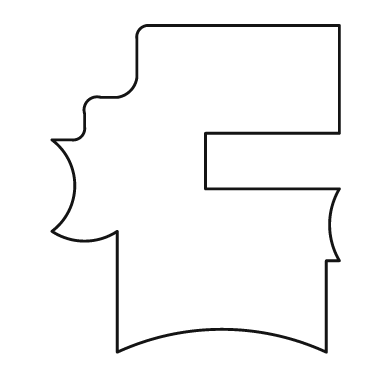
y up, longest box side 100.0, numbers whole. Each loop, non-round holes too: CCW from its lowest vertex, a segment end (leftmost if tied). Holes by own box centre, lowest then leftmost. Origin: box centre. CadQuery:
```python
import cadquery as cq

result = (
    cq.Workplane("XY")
    .moveTo(-24.0, -50.0)
    .threePointArc((8.0, -43.0), (40.0, -50.0))
    .lineTo(40.0, -22.0)
    .lineTo(44.0, -22.0)
    .threePointArc((41.0, -11.0), (44.0, 0.0))
    .lineTo(3.0, 0.0)
    .lineTo(3.0, 17.0)
    .lineTo(44.0, 17.0)
    .lineTo(44.0, 50.0)
    .lineTo(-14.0, 50.0)
    .threePointArc((-17.0, 49.0), (-18.0, 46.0))
    .lineTo(-18.0, 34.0)
    .threePointArc((-20.0, 30.0), (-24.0, 28.0))
    .lineTo(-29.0, 28.0)
    .threePointArc((-33.0, 27.0), (-34.0, 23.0))
    .lineTo(-34.0, 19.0)
    .threePointArc((-35.0, 16.0), (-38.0, 15.0))
    .lineTo(-44.0, 15.0)
    .threePointArc((-37.0, 1.0), (-44.0, -13.0))
    .threePointArc((-34.0, -16.0), (-24.0, -13.0))
    .close()
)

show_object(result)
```